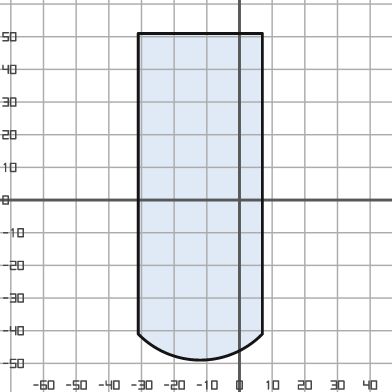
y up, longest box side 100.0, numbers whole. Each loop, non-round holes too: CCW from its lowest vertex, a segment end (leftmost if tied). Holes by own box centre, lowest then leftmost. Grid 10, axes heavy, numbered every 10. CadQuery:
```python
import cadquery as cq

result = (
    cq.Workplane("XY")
    .moveTo(-31.0, -41.0)
    .threePointArc((-12.0, -49.0), (7.0, -41.0))
    .lineTo(7.0, 51.0)
    .lineTo(-31.0, 51.0)
    .close()
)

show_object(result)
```